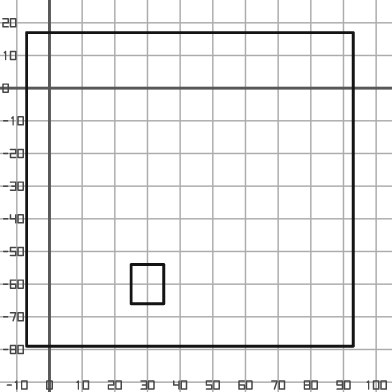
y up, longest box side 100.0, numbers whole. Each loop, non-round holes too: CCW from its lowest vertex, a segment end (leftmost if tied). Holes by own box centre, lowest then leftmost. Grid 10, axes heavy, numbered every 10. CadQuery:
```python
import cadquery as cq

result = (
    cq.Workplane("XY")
    .moveTo(-7.0, -79.0)
    .lineTo(93.0, -79.0)
    .lineTo(93.0, 17.0)
    .lineTo(-7.0, 17.0)
    .close()
    .moveTo(25.0, -66.0)
    .lineTo(35.0, -66.0)
    .lineTo(35.0, -54.0)
    .lineTo(25.0, -54.0)
    .close()
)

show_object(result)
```